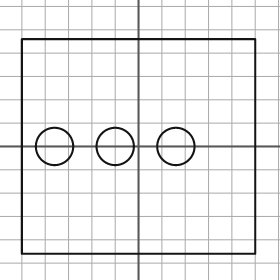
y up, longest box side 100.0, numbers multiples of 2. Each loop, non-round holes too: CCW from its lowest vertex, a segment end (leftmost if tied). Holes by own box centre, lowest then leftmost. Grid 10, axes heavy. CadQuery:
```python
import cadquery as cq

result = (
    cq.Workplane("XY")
    .moveTo(-50.0, -46.0)
    .lineTo(50.0, -46.0)
    .lineTo(50.0, 46.0)
    .lineTo(-50.0, 46.0)
    .close()
    .moveTo(-36.0, 0.0)
    .circle(8.0)
    .moveTo(-10.0, 0.0)
    .circle(8.0)
    .moveTo(16.0, 0.0)
    .circle(8.0)
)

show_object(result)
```